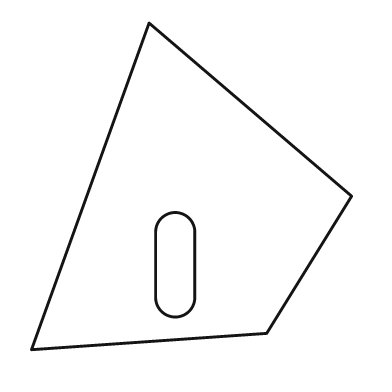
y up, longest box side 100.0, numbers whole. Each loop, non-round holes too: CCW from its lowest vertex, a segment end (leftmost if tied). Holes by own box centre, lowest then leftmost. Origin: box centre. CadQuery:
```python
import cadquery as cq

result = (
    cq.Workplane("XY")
    .moveTo(-49.0, -50.0)
    .lineTo(23.0, -45.0)
    .lineTo(49.0, -3.0)
    .lineTo(-13.0, 50.0)
    .close()
    .moveTo(-11.0, -34.0)
    .threePointArc((-5.0, -40.0), (1.0, -34.0))
    .lineTo(1.0, -14.0)
    .threePointArc((-5.0, -8.0), (-11.0, -14.0))
    .close()
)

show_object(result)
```